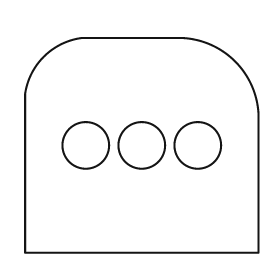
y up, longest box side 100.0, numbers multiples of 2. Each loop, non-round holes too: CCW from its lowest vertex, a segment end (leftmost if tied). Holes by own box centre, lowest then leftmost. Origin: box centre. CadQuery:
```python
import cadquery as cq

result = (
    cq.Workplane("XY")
    .moveTo(-50.0, -46.0)
    .lineTo(50.0, -46.0)
    .lineTo(50.0, 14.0)
    .threePointArc((40.0, 36.0), (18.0, 46.0))
    .lineTo(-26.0, 46.0)
    .threePointArc((-42.0, 38.0), (-50.0, 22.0))
    .close()
    .moveTo(-24.0, 0.0)
    .circle(10.0)
    .moveTo(0.0, 0.0)
    .circle(10.0)
    .moveTo(24.0, 0.0)
    .circle(10.0)
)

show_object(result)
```